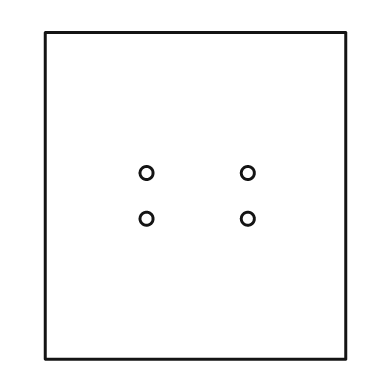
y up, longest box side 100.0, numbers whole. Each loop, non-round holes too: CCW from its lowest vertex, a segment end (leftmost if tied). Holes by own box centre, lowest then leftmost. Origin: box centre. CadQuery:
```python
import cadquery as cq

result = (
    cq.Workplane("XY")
    .moveTo(-46.0, -50.0)
    .lineTo(46.0, -50.0)
    .lineTo(46.0, 50.0)
    .lineTo(-46.0, 50.0)
    .close()
    .moveTo(-15.0, -7.0)
    .circle(2.0)
    .moveTo(16.0, -7.0)
    .circle(2.0)
    .moveTo(-15.0, 7.0)
    .circle(2.0)
    .moveTo(16.0, 7.0)
    .circle(2.0)
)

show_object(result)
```